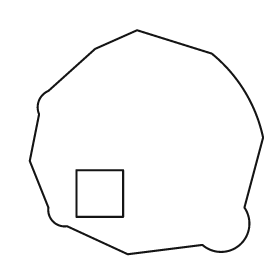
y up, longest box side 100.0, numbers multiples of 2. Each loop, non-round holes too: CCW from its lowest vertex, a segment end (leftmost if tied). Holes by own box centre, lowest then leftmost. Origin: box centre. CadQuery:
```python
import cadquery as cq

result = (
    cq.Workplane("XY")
    .moveTo(-8.0, -48.0)
    .lineTo(24.0, -44.0)
    .threePointArc((40.0, -44.0), (42.0, -28.0))
    .lineTo(50.0, 2.0)
    .threePointArc((42.0, 22.0), (28.0, 38.0))
    .lineTo(-4.0, 48.0)
    .lineTo(-22.0, 40.0)
    .lineTo(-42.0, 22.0)
    .threePointArc((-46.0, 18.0), (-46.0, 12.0))
    .lineTo(-50.0, -8.0)
    .lineTo(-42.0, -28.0)
    .threePointArc((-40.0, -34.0), (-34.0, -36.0))
    .close()
    .moveTo(-30.0, -32.0)
    .lineTo(-10.0, -32.0)
    .lineTo(-10.0, -12.0)
    .lineTo(-30.0, -12.0)
    .close()
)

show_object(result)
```